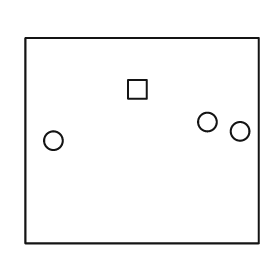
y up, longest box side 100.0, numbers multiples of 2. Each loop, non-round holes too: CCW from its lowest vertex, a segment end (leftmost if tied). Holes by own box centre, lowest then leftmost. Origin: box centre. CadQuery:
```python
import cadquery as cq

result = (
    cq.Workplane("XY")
    .moveTo(-50.0, -44.0)
    .lineTo(50.0, -44.0)
    .lineTo(50.0, 44.0)
    .lineTo(-50.0, 44.0)
    .close()
    .moveTo(-38.0, 0.0)
    .circle(4.0)
    .moveTo(42.0, 4.0)
    .circle(4.0)
    .moveTo(28.0, 8.0)
    .circle(4.0)
    .moveTo(-6.0, 18.0)
    .lineTo(2.0, 18.0)
    .lineTo(2.0, 26.0)
    .lineTo(-6.0, 26.0)
    .close()
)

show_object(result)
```